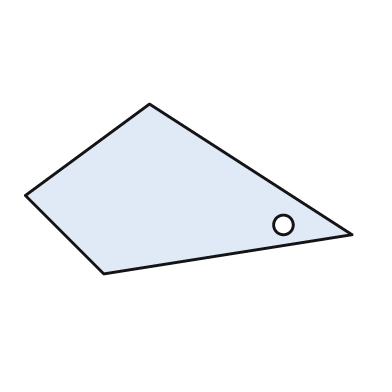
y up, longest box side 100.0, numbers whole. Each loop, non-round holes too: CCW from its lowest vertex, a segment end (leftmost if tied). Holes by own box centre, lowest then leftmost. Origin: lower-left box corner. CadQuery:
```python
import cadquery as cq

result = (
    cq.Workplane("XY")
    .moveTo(24.0, 0.0)
    .lineTo(100.0, 12.0)
    .lineTo(38.0, 52.0)
    .lineTo(0.0, 24.0)
    .close()
    .moveTo(79.0, 15.0)
    .circle(3.0)
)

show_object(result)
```